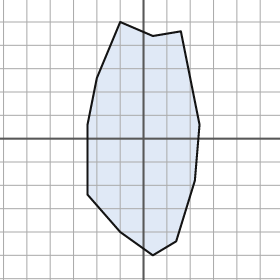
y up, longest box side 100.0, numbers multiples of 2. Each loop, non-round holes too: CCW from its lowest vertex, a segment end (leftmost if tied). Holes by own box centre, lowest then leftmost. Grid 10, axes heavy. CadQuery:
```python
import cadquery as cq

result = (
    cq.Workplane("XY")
    .moveTo(4.0, -50.0)
    .lineTo(14.0, -44.0)
    .lineTo(22.0, -18.0)
    .lineTo(24.0, 6.0)
    .lineTo(16.0, 46.0)
    .lineTo(4.0, 44.0)
    .lineTo(-10.0, 50.0)
    .lineTo(-20.0, 26.0)
    .lineTo(-24.0, 6.0)
    .lineTo(-24.0, -24.0)
    .lineTo(-10.0, -40.0)
    .close()
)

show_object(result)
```